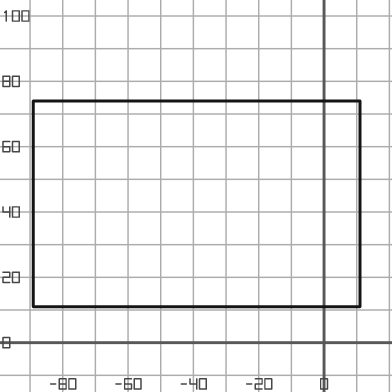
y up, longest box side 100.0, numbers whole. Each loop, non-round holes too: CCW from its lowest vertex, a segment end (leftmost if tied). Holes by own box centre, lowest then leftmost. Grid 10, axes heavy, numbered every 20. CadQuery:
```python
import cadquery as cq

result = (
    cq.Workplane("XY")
    .moveTo(-89.0, 11.0)
    .lineTo(11.0, 11.0)
    .lineTo(11.0, 74.0)
    .lineTo(-89.0, 74.0)
    .close()
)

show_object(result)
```